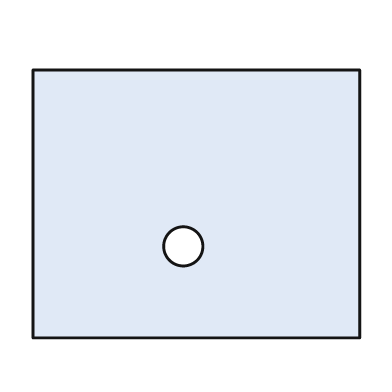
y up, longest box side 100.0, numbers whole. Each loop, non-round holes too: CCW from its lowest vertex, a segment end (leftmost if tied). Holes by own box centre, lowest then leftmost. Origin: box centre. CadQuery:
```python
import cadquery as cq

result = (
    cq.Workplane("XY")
    .moveTo(-50.0, -41.0)
    .lineTo(50.0, -41.0)
    .lineTo(50.0, 41.0)
    .lineTo(-50.0, 41.0)
    .close()
    .moveTo(-4.0, -13.0)
    .circle(6.0)
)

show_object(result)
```